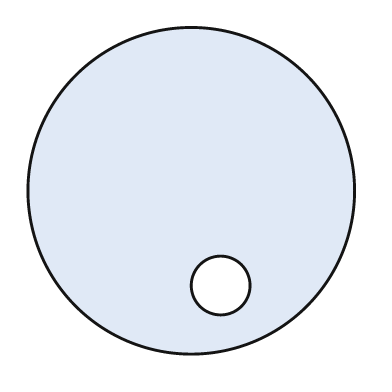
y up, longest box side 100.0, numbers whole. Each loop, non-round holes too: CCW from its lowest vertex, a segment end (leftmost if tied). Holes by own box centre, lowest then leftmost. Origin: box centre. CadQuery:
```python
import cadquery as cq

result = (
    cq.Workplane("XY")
    .moveTo(0.0, 0.0)
    .circle(50.0)
    .moveTo(9.0, -29.0)
    .circle(9.0)
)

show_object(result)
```